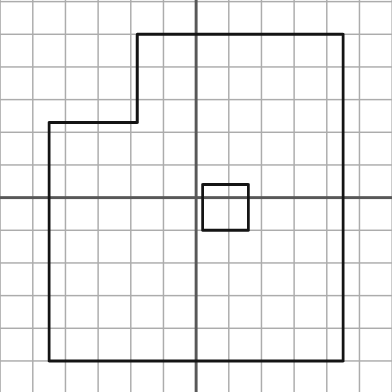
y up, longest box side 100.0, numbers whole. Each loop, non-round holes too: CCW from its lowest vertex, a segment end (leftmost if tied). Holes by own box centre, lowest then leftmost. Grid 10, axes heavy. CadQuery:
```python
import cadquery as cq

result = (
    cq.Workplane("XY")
    .moveTo(-45.0, -50.0)
    .lineTo(45.0, -50.0)
    .lineTo(45.0, 50.0)
    .lineTo(-18.0, 50.0)
    .lineTo(-18.0, 23.0)
    .lineTo(-45.0, 23.0)
    .close()
    .moveTo(2.0, -10.0)
    .lineTo(16.0, -10.0)
    .lineTo(16.0, 4.0)
    .lineTo(2.0, 4.0)
    .close()
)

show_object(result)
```